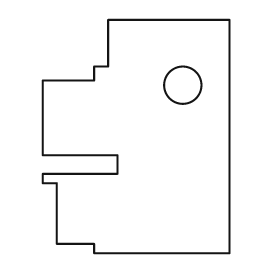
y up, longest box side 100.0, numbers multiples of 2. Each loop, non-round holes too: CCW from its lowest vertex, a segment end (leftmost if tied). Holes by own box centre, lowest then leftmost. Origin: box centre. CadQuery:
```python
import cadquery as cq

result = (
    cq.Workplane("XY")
    .moveTo(-18.0, -50.0)
    .lineTo(40.0, -50.0)
    .lineTo(40.0, 50.0)
    .lineTo(-12.0, 50.0)
    .lineTo(-12.0, 30.0)
    .lineTo(-18.0, 30.0)
    .lineTo(-18.0, 24.0)
    .lineTo(-40.0, 24.0)
    .lineTo(-40.0, -8.0)
    .lineTo(-8.0, -8.0)
    .lineTo(-8.0, -16.0)
    .lineTo(-40.0, -16.0)
    .lineTo(-40.0, -20.0)
    .lineTo(-34.0, -20.0)
    .lineTo(-34.0, -46.0)
    .lineTo(-18.0, -46.0)
    .close()
    .moveTo(20.0, 22.0)
    .circle(8.0)
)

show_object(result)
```